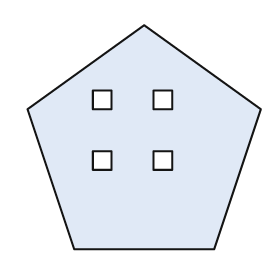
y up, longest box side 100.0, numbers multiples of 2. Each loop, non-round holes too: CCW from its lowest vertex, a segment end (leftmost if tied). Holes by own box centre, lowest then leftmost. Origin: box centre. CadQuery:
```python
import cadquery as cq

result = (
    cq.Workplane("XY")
    .moveTo(-30.0, -48.0)
    .lineTo(30.0, -48.0)
    .lineTo(50.0, 12.0)
    .lineTo(0.0, 48.0)
    .lineTo(-50.0, 12.0)
    .close()
    .moveTo(-22.0, -14.0)
    .lineTo(-14.0, -14.0)
    .lineTo(-14.0, -6.0)
    .lineTo(-22.0, -6.0)
    .close()
    .moveTo(4.0, -14.0)
    .lineTo(12.0, -14.0)
    .lineTo(12.0, -6.0)
    .lineTo(4.0, -6.0)
    .close()
    .moveTo(-22.0, 12.0)
    .lineTo(-14.0, 12.0)
    .lineTo(-14.0, 20.0)
    .lineTo(-22.0, 20.0)
    .close()
    .moveTo(4.0, 12.0)
    .lineTo(12.0, 12.0)
    .lineTo(12.0, 20.0)
    .lineTo(4.0, 20.0)
    .close()
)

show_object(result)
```